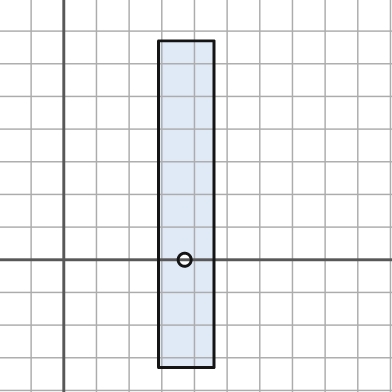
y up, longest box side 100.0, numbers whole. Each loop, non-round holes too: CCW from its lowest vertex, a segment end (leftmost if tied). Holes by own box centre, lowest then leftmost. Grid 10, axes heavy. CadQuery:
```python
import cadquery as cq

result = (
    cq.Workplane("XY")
    .moveTo(29.0, -33.0)
    .lineTo(46.0, -33.0)
    .lineTo(46.0, 67.0)
    .lineTo(29.0, 67.0)
    .close()
    .moveTo(37.0, 0.0)
    .circle(2.0)
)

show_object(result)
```